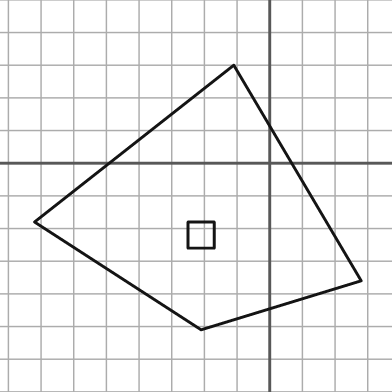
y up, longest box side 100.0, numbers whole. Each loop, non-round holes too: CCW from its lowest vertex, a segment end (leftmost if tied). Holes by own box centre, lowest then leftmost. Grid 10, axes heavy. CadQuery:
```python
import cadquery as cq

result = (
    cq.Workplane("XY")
    .moveTo(-21.0, -51.0)
    .lineTo(28.0, -36.0)
    .lineTo(-11.0, 30.0)
    .lineTo(-72.0, -18.0)
    .close()
    .moveTo(-25.0, -26.0)
    .lineTo(-17.0, -26.0)
    .lineTo(-17.0, -18.0)
    .lineTo(-25.0, -18.0)
    .close()
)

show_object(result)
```